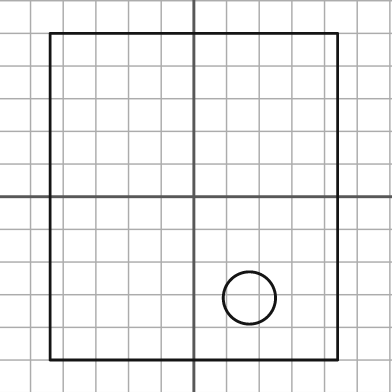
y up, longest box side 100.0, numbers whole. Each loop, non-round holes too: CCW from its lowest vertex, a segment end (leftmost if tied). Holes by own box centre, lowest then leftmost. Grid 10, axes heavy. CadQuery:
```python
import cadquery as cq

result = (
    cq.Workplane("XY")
    .moveTo(-44.0, -50.0)
    .lineTo(44.0, -50.0)
    .lineTo(44.0, 50.0)
    .lineTo(-44.0, 50.0)
    .close()
    .moveTo(17.0, -31.0)
    .circle(8.0)
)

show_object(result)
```